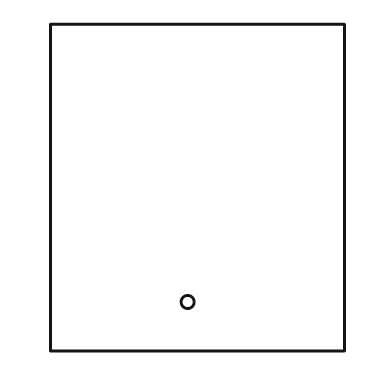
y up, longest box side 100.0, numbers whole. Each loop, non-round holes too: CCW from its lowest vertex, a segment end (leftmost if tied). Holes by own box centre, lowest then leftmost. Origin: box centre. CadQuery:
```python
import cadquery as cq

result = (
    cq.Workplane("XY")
    .moveTo(-45.0, -50.0)
    .lineTo(45.0, -50.0)
    .lineTo(45.0, 50.0)
    .lineTo(-45.0, 50.0)
    .close()
    .moveTo(-3.0, -35.0)
    .circle(2.0)
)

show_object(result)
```